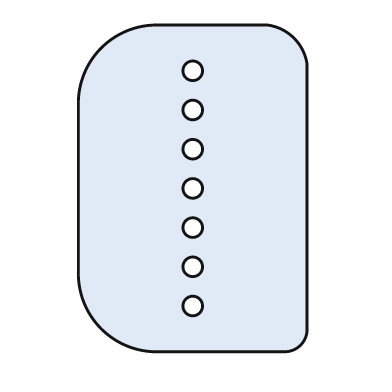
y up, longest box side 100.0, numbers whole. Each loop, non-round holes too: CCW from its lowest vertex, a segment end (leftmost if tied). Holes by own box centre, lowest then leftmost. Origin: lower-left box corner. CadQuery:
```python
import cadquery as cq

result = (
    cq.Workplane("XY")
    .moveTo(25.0, 0.0)
    .lineTo(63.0, 0.0)
    .threePointArc((68.0, 2.0), (70.0, 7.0))
    .lineTo(70.0, 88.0)
    .threePointArc((66.0, 96.0), (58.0, 100.0))
    .lineTo(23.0, 100.0)
    .threePointArc((7.0, 93.0), (0.0, 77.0))
    .lineTo(0.0, 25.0)
    .threePointArc((7.0, 7.0), (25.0, 0.0))
    .close()
    .moveTo(35.0, 14.0)
    .circle(3.0)
    .moveTo(35.0, 26.0)
    .circle(3.0)
    .moveTo(35.0, 38.0)
    .circle(3.0)
    .moveTo(35.0, 50.0)
    .circle(3.0)
    .moveTo(35.0, 62.0)
    .circle(3.0)
    .moveTo(35.0, 74.0)
    .circle(3.0)
    .moveTo(35.0, 86.0)
    .circle(3.0)
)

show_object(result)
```